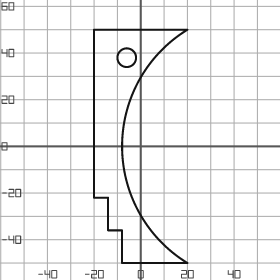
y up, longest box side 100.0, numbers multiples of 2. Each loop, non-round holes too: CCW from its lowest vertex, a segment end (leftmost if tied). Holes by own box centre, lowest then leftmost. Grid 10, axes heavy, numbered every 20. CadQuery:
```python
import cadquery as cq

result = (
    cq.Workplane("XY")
    .moveTo(-8.0, -50.0)
    .lineTo(20.0, -50.0)
    .threePointArc((-8.0, 0.0), (20.0, 50.0))
    .lineTo(-20.0, 50.0)
    .lineTo(-20.0, -22.0)
    .lineTo(-14.0, -22.0)
    .lineTo(-14.0, -36.0)
    .lineTo(-8.0, -36.0)
    .close()
    .moveTo(-6.0, 38.0)
    .circle(4.0)
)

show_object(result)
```